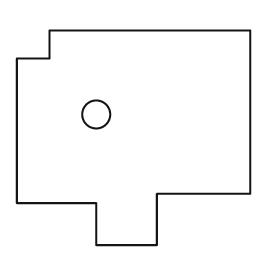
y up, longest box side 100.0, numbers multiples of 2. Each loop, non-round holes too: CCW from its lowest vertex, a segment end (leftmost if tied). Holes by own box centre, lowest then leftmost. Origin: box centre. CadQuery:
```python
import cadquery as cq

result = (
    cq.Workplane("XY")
    .moveTo(-16.0, -46.0)
    .lineTo(10.0, -46.0)
    .lineTo(10.0, -24.0)
    .lineTo(50.0, -24.0)
    .lineTo(50.0, 46.0)
    .lineTo(-36.0, 46.0)
    .lineTo(-36.0, 34.0)
    .lineTo(-50.0, 34.0)
    .lineTo(-50.0, -28.0)
    .lineTo(-16.0, -28.0)
    .close()
    .moveTo(-16.0, 10.0)
    .circle(6.0)
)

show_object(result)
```